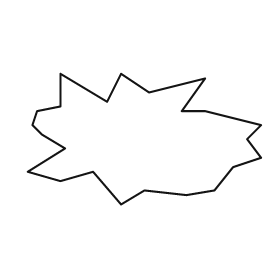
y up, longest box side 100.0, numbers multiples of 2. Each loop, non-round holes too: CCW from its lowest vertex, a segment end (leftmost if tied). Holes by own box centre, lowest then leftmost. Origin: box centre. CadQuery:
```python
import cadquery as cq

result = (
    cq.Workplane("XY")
    .moveTo(-10.0, -28.0)
    .lineTo(0.0, -22.0)
    .lineTo(18.0, -24.0)
    .lineTo(30.0, -22.0)
    .lineTo(38.0, -12.0)
    .lineTo(50.0, -8.0)
    .lineTo(44.0, 0.0)
    .lineTo(50.0, 6.0)
    .lineTo(26.0, 12.0)
    .lineTo(16.0, 12.0)
    .lineTo(26.0, 26.0)
    .lineTo(2.0, 20.0)
    .lineTo(-10.0, 28.0)
    .lineTo(-16.0, 16.0)
    .lineTo(-36.0, 28.0)
    .lineTo(-36.0, 14.0)
    .lineTo(-46.0, 12.0)
    .lineTo(-48.0, 6.0)
    .lineTo(-44.0, 2.0)
    .lineTo(-34.0, -4.0)
    .lineTo(-50.0, -14.0)
    .lineTo(-36.0, -18.0)
    .lineTo(-22.0, -14.0)
    .close()
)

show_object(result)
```